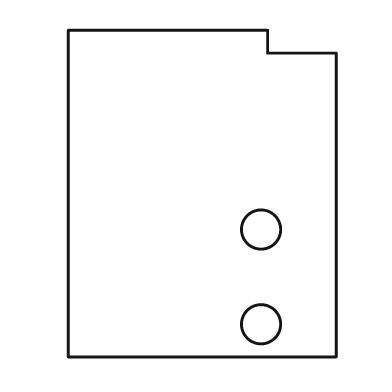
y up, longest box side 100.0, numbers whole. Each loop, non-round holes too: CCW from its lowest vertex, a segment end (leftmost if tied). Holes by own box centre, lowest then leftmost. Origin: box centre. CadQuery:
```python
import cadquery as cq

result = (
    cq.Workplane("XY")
    .moveTo(-41.0, -50.0)
    .lineTo(41.0, -50.0)
    .lineTo(41.0, 43.0)
    .lineTo(20.0, 43.0)
    .lineTo(20.0, 50.0)
    .lineTo(-41.0, 50.0)
    .close()
    .moveTo(18.0, -40.0)
    .circle(6.0)
    .moveTo(18.0, -11.0)
    .circle(6.0)
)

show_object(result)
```